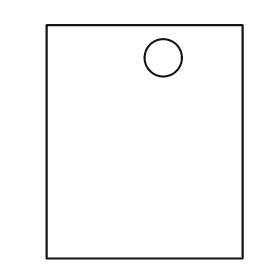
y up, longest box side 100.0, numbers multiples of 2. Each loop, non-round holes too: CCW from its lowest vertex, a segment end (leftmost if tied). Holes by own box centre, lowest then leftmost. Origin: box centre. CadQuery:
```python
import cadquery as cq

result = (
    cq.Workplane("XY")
    .moveTo(-42.0, -50.0)
    .lineTo(42.0, -50.0)
    .lineTo(42.0, 50.0)
    .lineTo(-42.0, 50.0)
    .close()
    .moveTo(8.0, 36.0)
    .circle(8.0)
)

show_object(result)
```